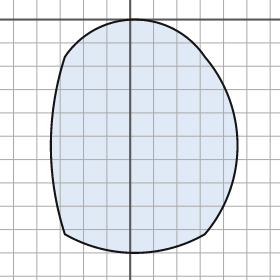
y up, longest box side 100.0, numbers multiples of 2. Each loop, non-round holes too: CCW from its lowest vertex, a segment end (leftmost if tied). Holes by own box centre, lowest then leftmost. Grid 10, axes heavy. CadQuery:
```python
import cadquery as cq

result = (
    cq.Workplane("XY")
    .moveTo(-28.0, -92.0)
    .threePointArc((2.0, -100.0), (32.0, -92.0))
    .threePointArc((46.0, -54.0), (32.0, -16.0))
    .threePointArc((2.0, 0.0), (-28.0, -16.0))
    .threePointArc((-34.0, -54.0), (-28.0, -92.0))
    .close()
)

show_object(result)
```